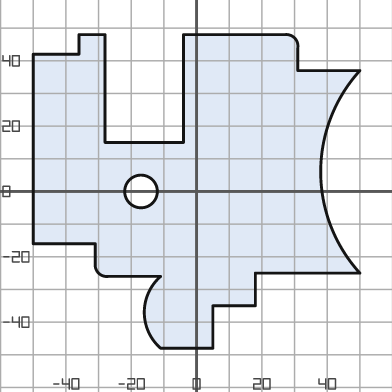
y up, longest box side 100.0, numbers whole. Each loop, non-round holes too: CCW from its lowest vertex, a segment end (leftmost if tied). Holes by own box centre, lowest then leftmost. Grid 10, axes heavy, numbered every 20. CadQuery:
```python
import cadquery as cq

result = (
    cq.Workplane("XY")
    .moveTo(-11.0, -48.0)
    .lineTo(5.0, -48.0)
    .lineTo(5.0, -35.0)
    .lineTo(18.0, -35.0)
    .lineTo(18.0, -25.0)
    .lineTo(50.0, -25.0)
    .threePointArc((38.0, 6.0), (50.0, 37.0))
    .lineTo(31.0, 37.0)
    .lineTo(31.0, 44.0)
    .threePointArc((30.0, 47.0), (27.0, 48.0))
    .lineTo(-4.0, 48.0)
    .lineTo(-4.0, 15.0)
    .lineTo(-28.0, 15.0)
    .lineTo(-28.0, 48.0)
    .lineTo(-36.0, 48.0)
    .lineTo(-36.0, 42.0)
    .lineTo(-50.0, 42.0)
    .lineTo(-50.0, -16.0)
    .lineTo(-31.0, -16.0)
    .lineTo(-31.0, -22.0)
    .threePointArc((-30.0, -25.0), (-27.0, -26.0))
    .lineTo(-11.0, -26.0)
    .threePointArc((-16.0, -37.0), (-11.0, -48.0))
    .close()
    .moveTo(-17.0, 0.0)
    .circle(5.0)
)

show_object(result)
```